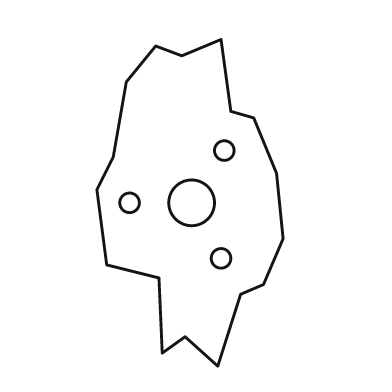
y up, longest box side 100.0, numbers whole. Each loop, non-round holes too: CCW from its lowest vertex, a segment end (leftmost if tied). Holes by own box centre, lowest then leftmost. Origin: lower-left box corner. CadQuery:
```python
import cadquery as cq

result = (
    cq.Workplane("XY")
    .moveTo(37.0, 0.0)
    .lineTo(44.0, 22.0)
    .lineTo(51.0, 25.0)
    .lineTo(57.0, 39.0)
    .lineTo(55.0, 59.0)
    .lineTo(48.0, 76.0)
    .lineTo(41.0, 78.0)
    .lineTo(38.0, 100.0)
    .lineTo(26.0, 95.0)
    .lineTo(18.0, 98.0)
    .lineTo(9.0, 87.0)
    .lineTo(5.0, 64.0)
    .lineTo(0.0, 54.0)
    .lineTo(3.0, 31.0)
    .lineTo(19.0, 27.0)
    .lineTo(20.0, 4.0)
    .lineTo(27.0, 9.0)
    .close()
    .moveTo(38.0, 33.0)
    .circle(3.0)
    .moveTo(10.0, 50.0)
    .circle(3.0)
    .moveTo(29.0, 50.0)
    .circle(7.0)
    .moveTo(39.0, 66.0)
    .circle(3.0)
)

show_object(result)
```